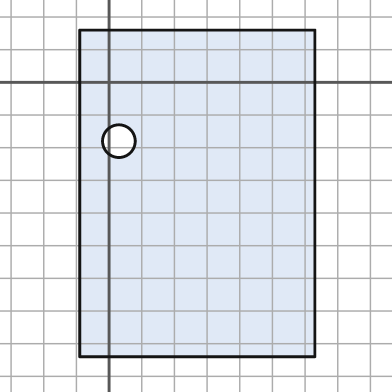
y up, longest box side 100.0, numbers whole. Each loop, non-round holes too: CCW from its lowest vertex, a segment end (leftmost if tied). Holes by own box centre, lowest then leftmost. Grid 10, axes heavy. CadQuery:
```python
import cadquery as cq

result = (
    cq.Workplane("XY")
    .moveTo(-9.0, -84.0)
    .lineTo(63.0, -84.0)
    .lineTo(63.0, 16.0)
    .lineTo(-9.0, 16.0)
    .close()
    .moveTo(3.0, -18.0)
    .circle(5.0)
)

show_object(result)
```